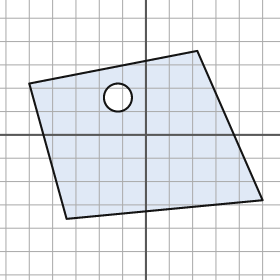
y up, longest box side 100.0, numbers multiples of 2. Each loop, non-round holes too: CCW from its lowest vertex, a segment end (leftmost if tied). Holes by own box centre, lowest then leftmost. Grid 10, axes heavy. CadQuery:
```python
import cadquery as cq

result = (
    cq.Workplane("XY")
    .moveTo(-34.0, -36.0)
    .lineTo(50.0, -28.0)
    .lineTo(22.0, 36.0)
    .lineTo(-50.0, 22.0)
    .close()
    .moveTo(-12.0, 16.0)
    .circle(6.0)
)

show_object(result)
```